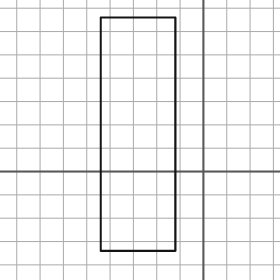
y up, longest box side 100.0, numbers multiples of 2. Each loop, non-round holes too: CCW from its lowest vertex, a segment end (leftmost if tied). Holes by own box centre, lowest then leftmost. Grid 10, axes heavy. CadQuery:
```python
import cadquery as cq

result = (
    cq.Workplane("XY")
    .moveTo(-44.0, -34.0)
    .lineTo(-12.0, -34.0)
    .lineTo(-12.0, 66.0)
    .lineTo(-44.0, 66.0)
    .close()
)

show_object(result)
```